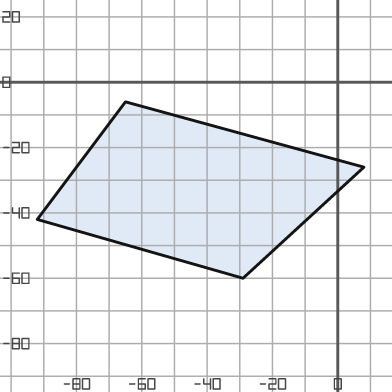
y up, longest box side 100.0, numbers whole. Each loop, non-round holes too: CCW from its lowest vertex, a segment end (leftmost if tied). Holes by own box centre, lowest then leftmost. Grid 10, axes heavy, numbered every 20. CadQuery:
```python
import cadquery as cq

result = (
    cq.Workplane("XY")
    .moveTo(-29.0, -60.0)
    .lineTo(8.0, -26.0)
    .lineTo(-65.0, -6.0)
    .lineTo(-92.0, -42.0)
    .close()
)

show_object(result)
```